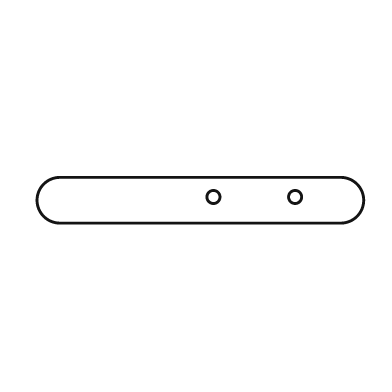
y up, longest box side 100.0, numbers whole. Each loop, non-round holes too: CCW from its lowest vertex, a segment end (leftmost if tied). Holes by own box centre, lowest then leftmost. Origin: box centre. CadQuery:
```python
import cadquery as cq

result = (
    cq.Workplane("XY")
    .moveTo(-43.0, -7.0)
    .lineTo(43.0, -7.0)
    .threePointArc((50.0, 0.0), (43.0, 7.0))
    .lineTo(-43.0, 7.0)
    .threePointArc((-50.0, 0.0), (-43.0, -7.0))
    .close()
    .moveTo(4.0, 1.0)
    .circle(2.0)
    .moveTo(29.0, 1.0)
    .circle(2.0)
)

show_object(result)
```